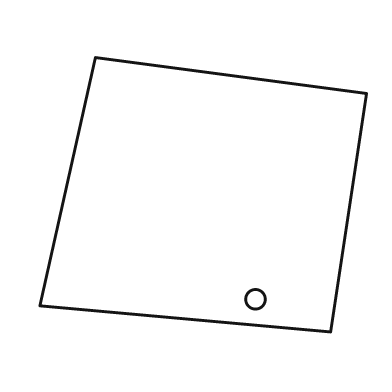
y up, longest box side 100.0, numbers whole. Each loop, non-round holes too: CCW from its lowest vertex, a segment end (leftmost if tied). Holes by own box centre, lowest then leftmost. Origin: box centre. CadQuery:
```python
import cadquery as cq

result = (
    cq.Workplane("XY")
    .moveTo(39.0, -42.0)
    .lineTo(50.0, 31.0)
    .lineTo(-33.0, 42.0)
    .lineTo(-50.0, -34.0)
    .close()
    .moveTo(16.0, -32.0)
    .circle(3.0)
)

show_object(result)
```